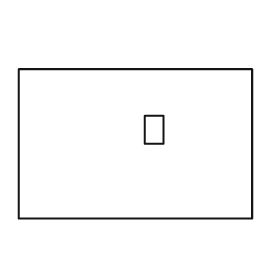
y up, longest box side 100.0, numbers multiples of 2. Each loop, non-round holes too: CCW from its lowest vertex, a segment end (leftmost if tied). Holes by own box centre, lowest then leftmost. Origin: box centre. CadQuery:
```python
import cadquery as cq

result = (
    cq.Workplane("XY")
    .moveTo(-50.0, -32.0)
    .lineTo(50.0, -32.0)
    .lineTo(50.0, 32.0)
    .lineTo(-50.0, 32.0)
    .close()
    .moveTo(4.0, 0.0)
    .lineTo(12.0, 0.0)
    .lineTo(12.0, 12.0)
    .lineTo(4.0, 12.0)
    .close()
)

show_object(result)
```